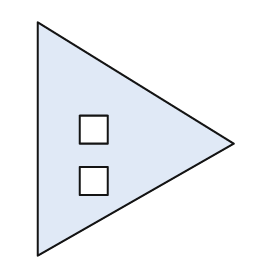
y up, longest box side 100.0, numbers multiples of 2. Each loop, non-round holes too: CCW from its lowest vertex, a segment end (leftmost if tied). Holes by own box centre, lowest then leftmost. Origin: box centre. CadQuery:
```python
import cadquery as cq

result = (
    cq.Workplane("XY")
    .moveTo(-42.0, -50.0)
    .lineTo(42.0, -2.0)
    .lineTo(-42.0, 50.0)
    .close()
    .moveTo(-24.0, -24.0)
    .lineTo(-12.0, -24.0)
    .lineTo(-12.0, -12.0)
    .lineTo(-24.0, -12.0)
    .close()
    .moveTo(-24.0, -2.0)
    .lineTo(-12.0, -2.0)
    .lineTo(-12.0, 10.0)
    .lineTo(-24.0, 10.0)
    .close()
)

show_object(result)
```